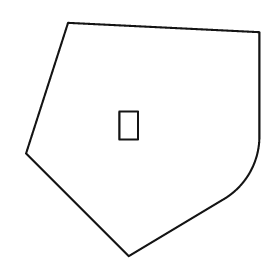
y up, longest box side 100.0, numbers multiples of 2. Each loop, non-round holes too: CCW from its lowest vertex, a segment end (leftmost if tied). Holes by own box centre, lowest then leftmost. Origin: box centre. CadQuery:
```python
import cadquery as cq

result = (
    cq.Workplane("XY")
    .moveTo(-6.0, -50.0)
    .lineTo(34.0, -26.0)
    .threePointArc((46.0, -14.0), (50.0, 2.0))
    .lineTo(50.0, 46.0)
    .lineTo(-32.0, 50.0)
    .lineTo(-50.0, -6.0)
    .close()
    .moveTo(-10.0, 0.0)
    .lineTo(-2.0, 0.0)
    .lineTo(-2.0, 12.0)
    .lineTo(-10.0, 12.0)
    .close()
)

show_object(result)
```